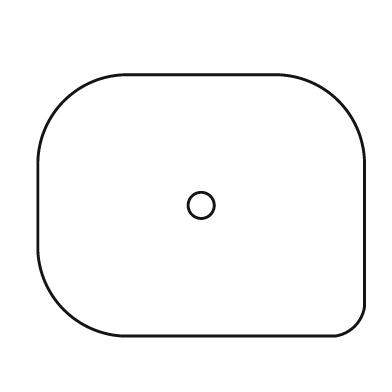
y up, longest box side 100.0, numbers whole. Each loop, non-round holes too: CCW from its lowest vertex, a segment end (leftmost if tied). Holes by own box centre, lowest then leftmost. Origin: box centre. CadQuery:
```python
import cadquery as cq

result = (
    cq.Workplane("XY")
    .moveTo(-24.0, -40.0)
    .lineTo(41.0, -40.0)
    .threePointArc((47.0, -37.0), (50.0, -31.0))
    .lineTo(50.0, 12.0)
    .threePointArc((42.0, 32.0), (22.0, 40.0))
    .lineTo(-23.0, 40.0)
    .threePointArc((-42.0, 32.0), (-50.0, 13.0))
    .lineTo(-50.0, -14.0)
    .threePointArc((-42.0, -32.0), (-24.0, -40.0))
    .close()
    .moveTo(0.0, 0.0)
    .circle(4.0)
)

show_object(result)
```